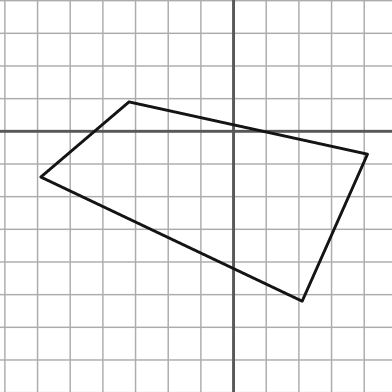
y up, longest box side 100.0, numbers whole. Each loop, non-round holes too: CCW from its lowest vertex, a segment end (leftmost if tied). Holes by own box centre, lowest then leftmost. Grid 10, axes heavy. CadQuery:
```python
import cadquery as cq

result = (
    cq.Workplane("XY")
    .moveTo(21.0, -52.0)
    .lineTo(41.0, -7.0)
    .lineTo(-32.0, 9.0)
    .lineTo(-59.0, -14.0)
    .close()
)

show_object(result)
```